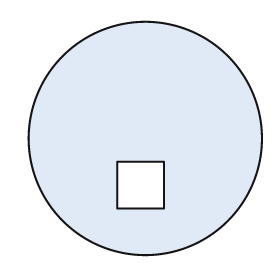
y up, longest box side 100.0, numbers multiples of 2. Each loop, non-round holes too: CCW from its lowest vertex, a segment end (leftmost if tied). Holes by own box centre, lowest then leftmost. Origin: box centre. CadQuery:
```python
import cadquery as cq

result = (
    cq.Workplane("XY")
    .moveTo(0.0, 0.0)
    .circle(50.0)
    .moveTo(-12.0, -30.0)
    .lineTo(8.0, -30.0)
    .lineTo(8.0, -10.0)
    .lineTo(-12.0, -10.0)
    .close()
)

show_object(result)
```